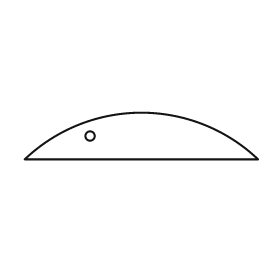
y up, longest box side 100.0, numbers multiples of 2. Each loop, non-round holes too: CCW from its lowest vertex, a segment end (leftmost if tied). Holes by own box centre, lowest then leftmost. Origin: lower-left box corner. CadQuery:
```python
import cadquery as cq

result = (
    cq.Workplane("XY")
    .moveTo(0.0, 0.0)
    .lineTo(100.0, 0.0)
    .threePointArc((50.0, 20.0), (0.0, 0.0))
    .close()
    .moveTo(28.0, 10.0)
    .circle(2.0)
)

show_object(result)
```